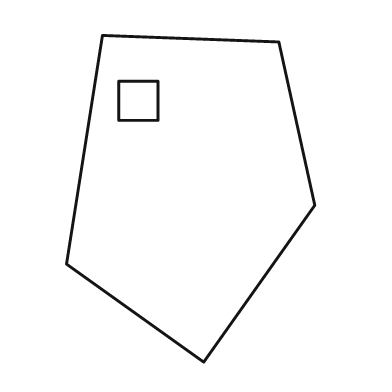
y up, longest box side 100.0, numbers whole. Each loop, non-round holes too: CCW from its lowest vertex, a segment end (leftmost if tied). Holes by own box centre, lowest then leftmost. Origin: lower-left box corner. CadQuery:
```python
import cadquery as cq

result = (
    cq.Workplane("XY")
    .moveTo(42.0, 0.0)
    .lineTo(76.0, 48.0)
    .lineTo(65.0, 98.0)
    .lineTo(11.0, 100.0)
    .lineTo(0.0, 30.0)
    .close()
    .moveTo(16.0, 74.0)
    .lineTo(28.0, 74.0)
    .lineTo(28.0, 86.0)
    .lineTo(16.0, 86.0)
    .close()
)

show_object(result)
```